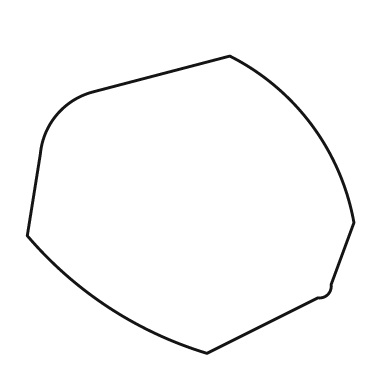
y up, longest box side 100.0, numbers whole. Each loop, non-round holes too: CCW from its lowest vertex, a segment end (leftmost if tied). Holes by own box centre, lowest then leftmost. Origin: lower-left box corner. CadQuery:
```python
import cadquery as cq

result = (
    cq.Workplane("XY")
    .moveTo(55.0, 0.0)
    .lineTo(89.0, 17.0)
    .threePointArc((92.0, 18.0), (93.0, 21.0))
    .lineTo(100.0, 40.0)
    .threePointArc((87.0, 70.0), (62.0, 91.0))
    .lineTo(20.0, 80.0)
    .threePointArc((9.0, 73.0), (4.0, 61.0))
    .lineTo(0.0, 36.0)
    .threePointArc((25.0, 14.0), (55.0, 0.0))
    .close()
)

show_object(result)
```